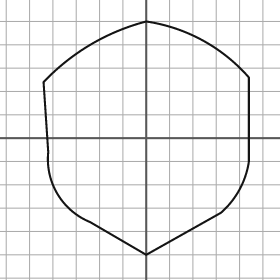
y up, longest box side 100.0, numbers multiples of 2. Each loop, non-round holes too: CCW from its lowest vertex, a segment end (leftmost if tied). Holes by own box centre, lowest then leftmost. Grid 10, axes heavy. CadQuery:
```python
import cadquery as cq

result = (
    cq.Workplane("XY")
    .moveTo(0.0, -50.0)
    .lineTo(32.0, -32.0)
    .threePointArc((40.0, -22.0), (44.0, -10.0))
    .lineTo(44.0, 26.0)
    .threePointArc((24.0, 42.0), (0.0, 50.0))
    .threePointArc((-24.0, 40.0), (-44.0, 24.0))
    .lineTo(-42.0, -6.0)
    .threePointArc((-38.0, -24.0), (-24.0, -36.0))
    .close()
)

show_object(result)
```